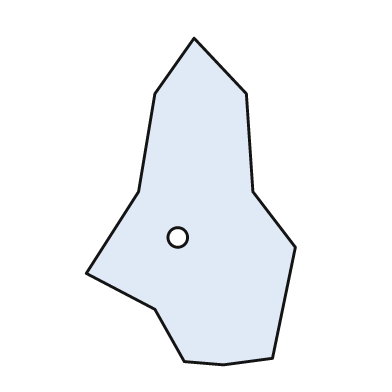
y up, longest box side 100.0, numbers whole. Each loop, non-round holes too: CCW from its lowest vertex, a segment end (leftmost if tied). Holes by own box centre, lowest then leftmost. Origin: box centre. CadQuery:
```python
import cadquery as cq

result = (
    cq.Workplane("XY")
    .moveTo(10.0, -50.0)
    .lineTo(25.0, -48.0)
    .lineTo(32.0, -14.0)
    .lineTo(19.0, 3.0)
    .lineTo(17.0, 33.0)
    .lineTo(1.0, 50.0)
    .lineTo(-11.0, 33.0)
    .lineTo(-16.0, 3.0)
    .lineTo(-32.0, -22.0)
    .lineTo(-11.0, -33.0)
    .lineTo(-2.0, -49.0)
    .close()
    .moveTo(-4.0, -11.0)
    .circle(3.0)
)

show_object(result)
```